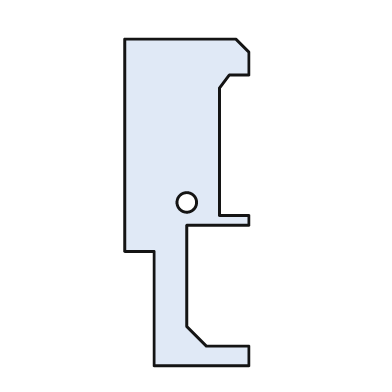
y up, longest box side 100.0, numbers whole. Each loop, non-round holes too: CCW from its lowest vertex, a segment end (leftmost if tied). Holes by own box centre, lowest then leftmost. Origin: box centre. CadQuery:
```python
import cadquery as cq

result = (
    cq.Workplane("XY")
    .moveTo(-10.0, -50.0)
    .lineTo(19.0, -50.0)
    .lineTo(19.0, -44.0)
    .lineTo(6.0, -44.0)
    .lineTo(0.0, -38.0)
    .lineTo(0.0, -7.0)
    .lineTo(19.0, -7.0)
    .lineTo(19.0, -4.0)
    .lineTo(10.0, -4.0)
    .lineTo(10.0, 35.0)
    .lineTo(13.0, 39.0)
    .lineTo(19.0, 39.0)
    .lineTo(19.0, 46.0)
    .lineTo(15.0, 50.0)
    .lineTo(-19.0, 50.0)
    .lineTo(-19.0, -15.0)
    .lineTo(-10.0, -15.0)
    .close()
    .moveTo(0.0, 0.0)
    .circle(3.0)
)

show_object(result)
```